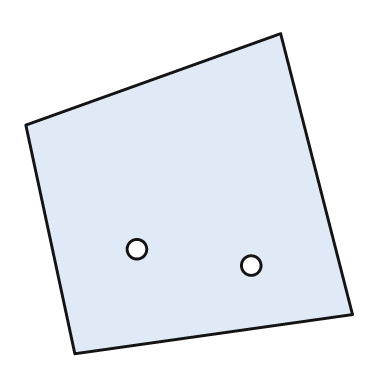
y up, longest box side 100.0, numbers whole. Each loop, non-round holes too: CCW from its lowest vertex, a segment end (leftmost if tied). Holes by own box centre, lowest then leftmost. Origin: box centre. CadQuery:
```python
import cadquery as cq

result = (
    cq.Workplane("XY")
    .moveTo(-35.0, -49.0)
    .lineTo(50.0, -37.0)
    .lineTo(28.0, 49.0)
    .lineTo(-50.0, 21.0)
    .close()
    .moveTo(19.0, -22.0)
    .circle(3.0)
    .moveTo(-16.0, -17.0)
    .circle(3.0)
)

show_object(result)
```